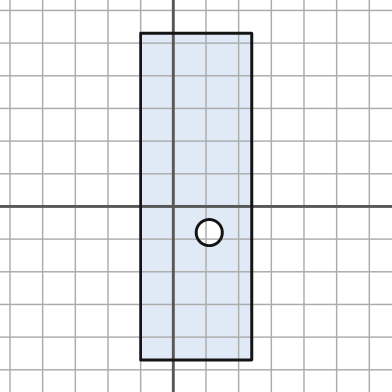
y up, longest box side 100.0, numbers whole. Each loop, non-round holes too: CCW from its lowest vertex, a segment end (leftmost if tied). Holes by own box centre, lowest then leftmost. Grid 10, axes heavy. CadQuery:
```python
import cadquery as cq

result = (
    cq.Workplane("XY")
    .moveTo(-10.0, -47.0)
    .lineTo(24.0, -47.0)
    .lineTo(24.0, 53.0)
    .lineTo(-10.0, 53.0)
    .close()
    .moveTo(11.0, -8.0)
    .circle(4.0)
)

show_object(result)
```